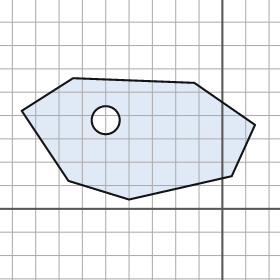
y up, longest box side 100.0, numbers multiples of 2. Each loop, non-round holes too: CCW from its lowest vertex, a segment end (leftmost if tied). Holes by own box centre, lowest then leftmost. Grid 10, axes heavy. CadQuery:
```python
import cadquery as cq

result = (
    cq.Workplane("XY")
    .moveTo(-40.0, 4.0)
    .lineTo(4.0, 14.0)
    .lineTo(14.0, 36.0)
    .lineTo(-12.0, 54.0)
    .lineTo(-64.0, 56.0)
    .lineTo(-86.0, 42.0)
    .lineTo(-66.0, 12.0)
    .close()
    .moveTo(-50.0, 38.0)
    .circle(6.0)
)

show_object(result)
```